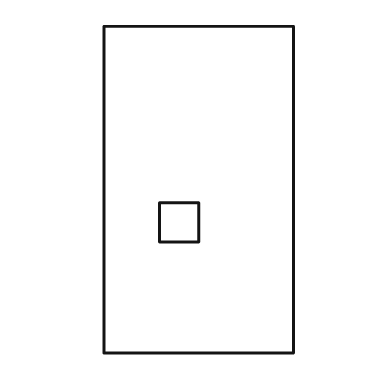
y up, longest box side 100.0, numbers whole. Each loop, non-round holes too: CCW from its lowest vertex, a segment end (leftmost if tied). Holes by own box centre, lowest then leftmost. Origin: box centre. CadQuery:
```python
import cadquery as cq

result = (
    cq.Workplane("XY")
    .moveTo(-29.0, -50.0)
    .lineTo(29.0, -50.0)
    .lineTo(29.0, 50.0)
    .lineTo(-29.0, 50.0)
    .close()
    .moveTo(-12.0, -16.0)
    .lineTo(0.0, -16.0)
    .lineTo(0.0, -4.0)
    .lineTo(-12.0, -4.0)
    .close()
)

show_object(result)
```